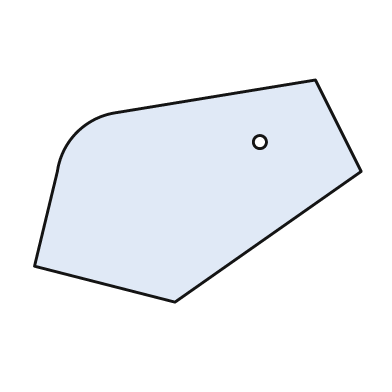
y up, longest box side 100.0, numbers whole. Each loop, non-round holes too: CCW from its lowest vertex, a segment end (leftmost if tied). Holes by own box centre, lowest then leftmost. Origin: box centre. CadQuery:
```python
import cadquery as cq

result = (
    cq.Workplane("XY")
    .moveTo(-7.0, -34.0)
    .lineTo(50.0, 6.0)
    .lineTo(36.0, 34.0)
    .lineTo(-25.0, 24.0)
    .threePointArc((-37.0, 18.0), (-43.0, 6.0))
    .lineTo(-50.0, -23.0)
    .close()
    .moveTo(19.0, 15.0)
    .circle(2.0)
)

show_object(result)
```